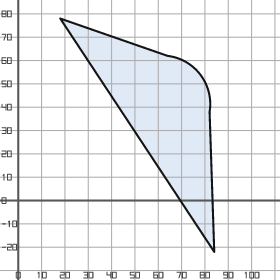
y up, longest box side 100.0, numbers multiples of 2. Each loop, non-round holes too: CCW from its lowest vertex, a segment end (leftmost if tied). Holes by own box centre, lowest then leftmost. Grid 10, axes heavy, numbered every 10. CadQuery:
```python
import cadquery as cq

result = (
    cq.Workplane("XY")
    .moveTo(84.0, -22.0)
    .lineTo(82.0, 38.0)
    .threePointArc((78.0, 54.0), (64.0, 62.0))
    .lineTo(18.0, 78.0)
    .close()
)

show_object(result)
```